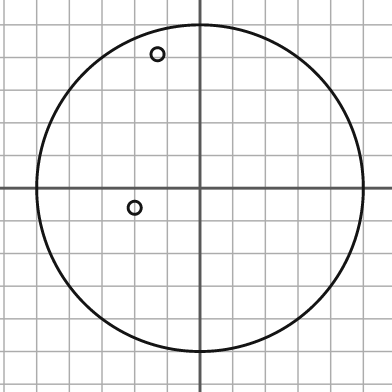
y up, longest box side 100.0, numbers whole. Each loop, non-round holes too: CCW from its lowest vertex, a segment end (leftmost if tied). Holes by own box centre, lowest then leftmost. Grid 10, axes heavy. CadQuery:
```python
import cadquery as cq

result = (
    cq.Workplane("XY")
    .moveTo(0.0, 0.0)
    .circle(50.0)
    .moveTo(-20.0, -6.0)
    .circle(2.0)
    .moveTo(-13.0, 41.0)
    .circle(2.0)
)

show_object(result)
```